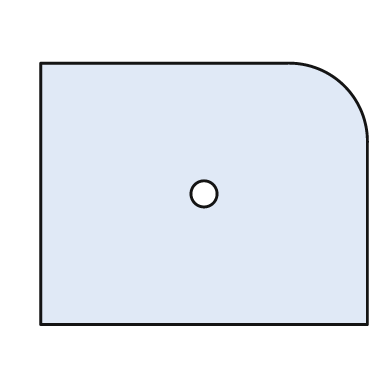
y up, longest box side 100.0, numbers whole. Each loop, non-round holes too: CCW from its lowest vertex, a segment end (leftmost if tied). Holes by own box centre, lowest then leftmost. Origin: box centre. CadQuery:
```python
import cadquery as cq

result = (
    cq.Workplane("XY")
    .moveTo(-50.0, -40.0)
    .lineTo(50.0, -40.0)
    .lineTo(50.0, 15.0)
    .threePointArc((43.0, 33.0), (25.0, 40.0))
    .lineTo(-50.0, 40.0)
    .close()
    .moveTo(0.0, 0.0)
    .circle(4.0)
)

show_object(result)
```